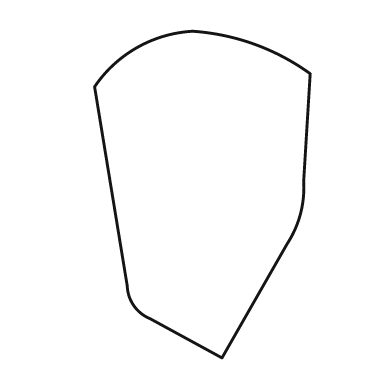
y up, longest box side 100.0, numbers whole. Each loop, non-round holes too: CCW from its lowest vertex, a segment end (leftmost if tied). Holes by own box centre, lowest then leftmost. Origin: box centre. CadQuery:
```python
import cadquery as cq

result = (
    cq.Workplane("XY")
    .moveTo(6.0, -50.0)
    .lineTo(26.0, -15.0)
    .threePointArc((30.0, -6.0), (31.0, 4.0))
    .lineTo(33.0, 37.0)
    .threePointArc((16.0, 46.0), (-3.0, 50.0))
    .threePointArc((-20.0, 45.0), (-33.0, 33.0))
    .lineTo(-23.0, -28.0)
    .threePointArc((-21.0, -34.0), (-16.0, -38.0))
    .close()
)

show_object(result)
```